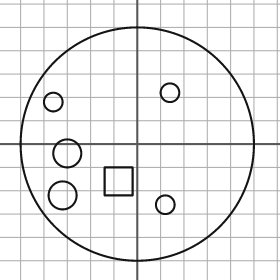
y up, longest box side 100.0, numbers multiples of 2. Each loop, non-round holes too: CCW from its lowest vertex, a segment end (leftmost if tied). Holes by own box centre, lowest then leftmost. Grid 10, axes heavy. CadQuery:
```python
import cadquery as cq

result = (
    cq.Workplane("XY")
    .moveTo(0.0, 0.0)
    .circle(50.0)
    .moveTo(12.0, -26.0)
    .circle(4.0)
    .moveTo(-32.0, -22.0)
    .circle(6.0)
    .moveTo(-14.0, -22.0)
    .lineTo(-2.0, -22.0)
    .lineTo(-2.0, -10.0)
    .lineTo(-14.0, -10.0)
    .close()
    .moveTo(-30.0, -4.0)
    .circle(6.0)
    .moveTo(-36.0, 18.0)
    .circle(4.0)
    .moveTo(14.0, 22.0)
    .circle(4.0)
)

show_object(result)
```